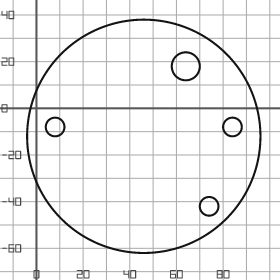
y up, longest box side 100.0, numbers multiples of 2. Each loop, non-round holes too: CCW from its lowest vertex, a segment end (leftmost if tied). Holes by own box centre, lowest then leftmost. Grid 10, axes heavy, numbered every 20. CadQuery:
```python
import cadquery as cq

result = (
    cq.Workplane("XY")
    .moveTo(46.0, -12.0)
    .circle(50.0)
    .moveTo(74.0, -42.0)
    .circle(4.0)
    .moveTo(8.0, -8.0)
    .circle(4.0)
    .moveTo(84.0, -8.0)
    .circle(4.0)
    .moveTo(64.0, 18.0)
    .circle(6.0)
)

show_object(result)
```